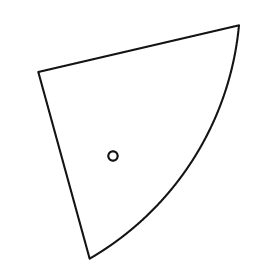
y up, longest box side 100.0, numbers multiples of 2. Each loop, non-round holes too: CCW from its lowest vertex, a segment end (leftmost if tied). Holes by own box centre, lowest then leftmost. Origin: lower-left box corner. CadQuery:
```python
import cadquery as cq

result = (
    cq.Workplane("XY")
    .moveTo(22.0, 0.0)
    .threePointArc((66.0, 42.0), (86.0, 100.0))
    .lineTo(0.0, 80.0)
    .close()
    .moveTo(32.0, 44.0)
    .circle(2.0)
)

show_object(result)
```